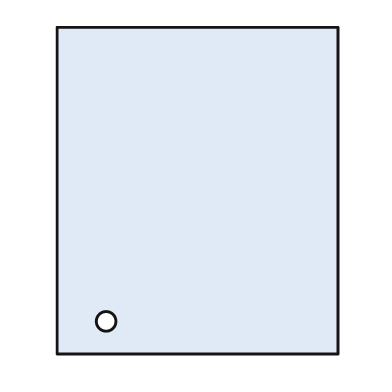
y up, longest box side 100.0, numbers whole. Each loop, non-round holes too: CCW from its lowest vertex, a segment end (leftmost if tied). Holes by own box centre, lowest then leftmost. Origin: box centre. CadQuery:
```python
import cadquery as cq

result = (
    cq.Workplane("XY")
    .moveTo(-43.0, -50.0)
    .lineTo(43.0, -50.0)
    .lineTo(43.0, 50.0)
    .lineTo(-43.0, 50.0)
    .close()
    .moveTo(-28.0, -40.0)
    .circle(3.0)
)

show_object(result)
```